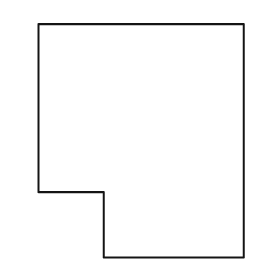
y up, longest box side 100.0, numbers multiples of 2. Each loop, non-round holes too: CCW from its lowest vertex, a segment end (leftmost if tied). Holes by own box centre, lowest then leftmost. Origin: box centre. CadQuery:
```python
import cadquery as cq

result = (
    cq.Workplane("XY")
    .moveTo(-16.0, -50.0)
    .lineTo(44.0, -50.0)
    .lineTo(44.0, 50.0)
    .lineTo(-44.0, 50.0)
    .lineTo(-44.0, -22.0)
    .lineTo(-16.0, -22.0)
    .close()
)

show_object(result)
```